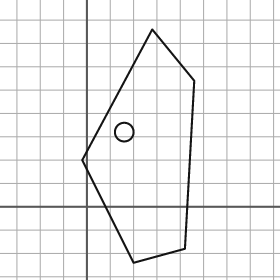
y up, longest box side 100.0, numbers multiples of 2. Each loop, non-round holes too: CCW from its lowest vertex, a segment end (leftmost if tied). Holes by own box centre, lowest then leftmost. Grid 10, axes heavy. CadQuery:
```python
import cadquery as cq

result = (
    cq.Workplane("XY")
    .moveTo(20.0, -24.0)
    .lineTo(42.0, -18.0)
    .lineTo(46.0, 54.0)
    .lineTo(28.0, 76.0)
    .lineTo(-2.0, 20.0)
    .close()
    .moveTo(16.0, 32.0)
    .circle(4.0)
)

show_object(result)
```